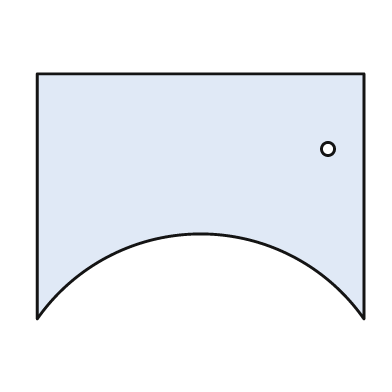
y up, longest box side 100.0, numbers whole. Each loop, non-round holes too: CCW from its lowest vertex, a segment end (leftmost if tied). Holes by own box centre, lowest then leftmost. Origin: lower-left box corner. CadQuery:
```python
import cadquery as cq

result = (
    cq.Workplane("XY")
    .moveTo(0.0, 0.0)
    .threePointArc((50.0, 26.0), (100.0, 0.0))
    .lineTo(100.0, 75.0)
    .lineTo(0.0, 75.0)
    .close()
    .moveTo(89.0, 52.0)
    .circle(2.0)
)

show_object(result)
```